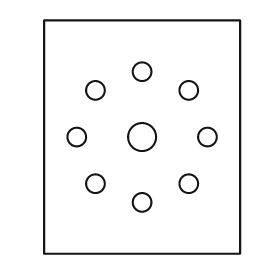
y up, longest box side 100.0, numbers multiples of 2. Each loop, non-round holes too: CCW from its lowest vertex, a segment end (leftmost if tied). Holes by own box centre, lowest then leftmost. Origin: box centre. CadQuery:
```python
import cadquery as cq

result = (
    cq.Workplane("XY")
    .moveTo(-42.0, -50.0)
    .lineTo(42.0, -50.0)
    .lineTo(42.0, 50.0)
    .lineTo(-42.0, 50.0)
    .close()
    .moveTo(0.0, -28.0)
    .circle(4.0)
    .moveTo(-20.0, -20.0)
    .circle(4.0)
    .moveTo(20.0, -20.0)
    .circle(4.0)
    .moveTo(-28.0, 0.0)
    .circle(4.0)
    .moveTo(0.0, 0.0)
    .circle(6.0)
    .moveTo(28.0, 0.0)
    .circle(4.0)
    .moveTo(-20.0, 20.0)
    .circle(4.0)
    .moveTo(20.0, 20.0)
    .circle(4.0)
    .moveTo(0.0, 28.0)
    .circle(4.0)
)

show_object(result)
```